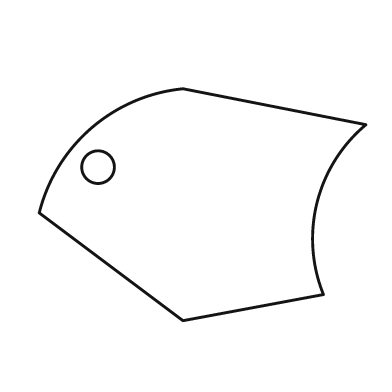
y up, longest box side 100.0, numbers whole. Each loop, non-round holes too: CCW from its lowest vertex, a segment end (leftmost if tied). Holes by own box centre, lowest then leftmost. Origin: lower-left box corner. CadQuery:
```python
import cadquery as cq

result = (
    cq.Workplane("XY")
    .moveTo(44.0, 0.0)
    .lineTo(87.0, 8.0)
    .threePointArc((85.0, 36.0), (100.0, 60.0))
    .lineTo(44.0, 71.0)
    .threePointArc((16.0, 59.0), (0.0, 33.0))
    .close()
    .moveTo(18.0, 47.0)
    .circle(5.0)
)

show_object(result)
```